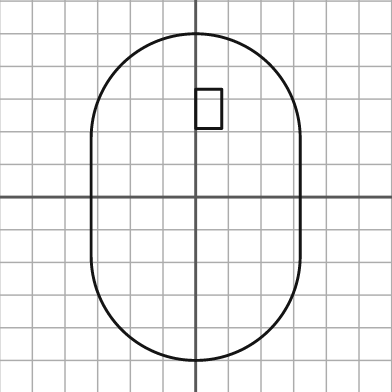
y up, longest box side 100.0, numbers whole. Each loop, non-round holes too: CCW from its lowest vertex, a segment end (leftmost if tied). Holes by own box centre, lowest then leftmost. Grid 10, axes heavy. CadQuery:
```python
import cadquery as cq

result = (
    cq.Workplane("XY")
    .moveTo(-32.0, -18.0)
    .threePointArc((0.0, -50.0), (32.0, -18.0))
    .lineTo(32.0, 18.0)
    .threePointArc((0.0, 50.0), (-32.0, 18.0))
    .close()
    .moveTo(0.0, 21.0)
    .lineTo(8.0, 21.0)
    .lineTo(8.0, 33.0)
    .lineTo(0.0, 33.0)
    .close()
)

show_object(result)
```